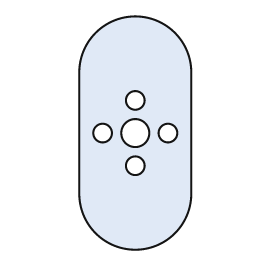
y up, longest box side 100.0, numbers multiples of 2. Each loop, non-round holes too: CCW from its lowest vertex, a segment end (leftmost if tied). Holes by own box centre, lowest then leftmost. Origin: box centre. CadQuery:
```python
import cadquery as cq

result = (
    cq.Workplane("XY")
    .moveTo(-24.0, -26.0)
    .threePointArc((0.0, -50.0), (24.0, -26.0))
    .lineTo(24.0, 26.0)
    .threePointArc((0.0, 50.0), (-24.0, 26.0))
    .close()
    .moveTo(0.0, -14.0)
    .circle(4.0)
    .moveTo(-14.0, 0.0)
    .circle(4.0)
    .moveTo(0.0, 0.0)
    .circle(6.0)
    .moveTo(14.0, 0.0)
    .circle(4.0)
    .moveTo(0.0, 14.0)
    .circle(4.0)
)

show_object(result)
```